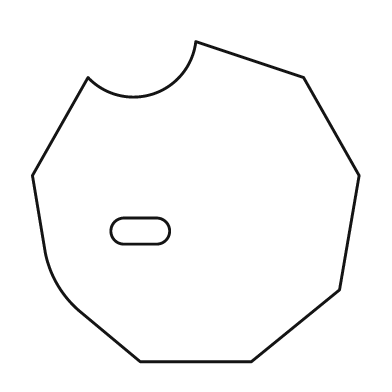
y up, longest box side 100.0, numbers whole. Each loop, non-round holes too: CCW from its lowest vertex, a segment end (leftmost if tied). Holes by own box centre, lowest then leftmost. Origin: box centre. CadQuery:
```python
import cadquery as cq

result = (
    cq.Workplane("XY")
    .moveTo(-17.0, -49.0)
    .lineTo(17.0, -49.0)
    .lineTo(44.0, -27.0)
    .lineTo(50.0, 8.0)
    .lineTo(33.0, 38.0)
    .lineTo(0.0, 49.0)
    .threePointArc((-13.0, 33.0), (-33.0, 38.0))
    .lineTo(-50.0, 8.0)
    .lineTo(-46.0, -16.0)
    .threePointArc((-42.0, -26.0), (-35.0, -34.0))
    .close()
    .moveTo(-22.0, -13.0)
    .lineTo(-12.0, -13.0)
    .threePointArc((-8.0, -9.0), (-12.0, -5.0))
    .lineTo(-22.0, -5.0)
    .threePointArc((-26.0, -9.0), (-22.0, -13.0))
    .close()
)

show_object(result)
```